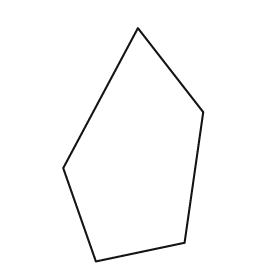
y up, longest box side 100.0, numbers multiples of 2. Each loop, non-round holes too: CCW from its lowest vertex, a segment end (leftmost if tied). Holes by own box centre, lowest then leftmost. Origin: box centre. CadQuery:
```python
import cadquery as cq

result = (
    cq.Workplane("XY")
    .moveTo(-16.0, -50.0)
    .lineTo(22.0, -42.0)
    .lineTo(30.0, 14.0)
    .lineTo(2.0, 50.0)
    .lineTo(-30.0, -10.0)
    .close()
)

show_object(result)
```